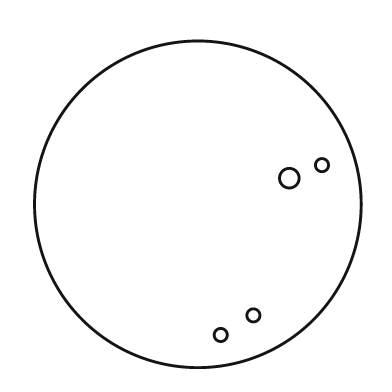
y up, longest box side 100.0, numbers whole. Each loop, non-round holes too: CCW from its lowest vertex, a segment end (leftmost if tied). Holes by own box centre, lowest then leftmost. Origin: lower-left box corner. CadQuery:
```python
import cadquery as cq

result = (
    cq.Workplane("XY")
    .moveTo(50.0, 50.0)
    .circle(50.0)
    .moveTo(57.0, 10.0)
    .circle(2.0)
    .moveTo(67.0, 16.0)
    .circle(2.0)
    .moveTo(78.0, 58.0)
    .circle(3.0)
    .moveTo(88.0, 62.0)
    .circle(2.0)
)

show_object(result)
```